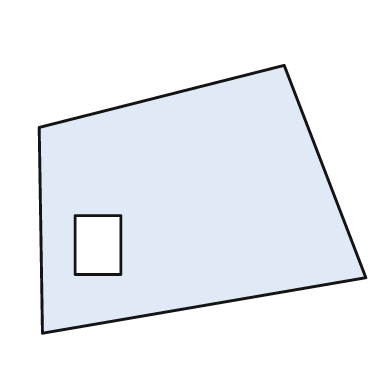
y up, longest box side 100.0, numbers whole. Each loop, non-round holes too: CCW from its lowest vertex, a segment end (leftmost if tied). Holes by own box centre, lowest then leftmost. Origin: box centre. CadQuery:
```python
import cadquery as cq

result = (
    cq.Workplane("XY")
    .moveTo(-49.0, -41.0)
    .lineTo(50.0, -24.0)
    .lineTo(25.0, 41.0)
    .lineTo(-50.0, 22.0)
    .close()
    .moveTo(-39.0, -23.0)
    .lineTo(-25.0, -23.0)
    .lineTo(-25.0, -5.0)
    .lineTo(-39.0, -5.0)
    .close()
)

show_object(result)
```